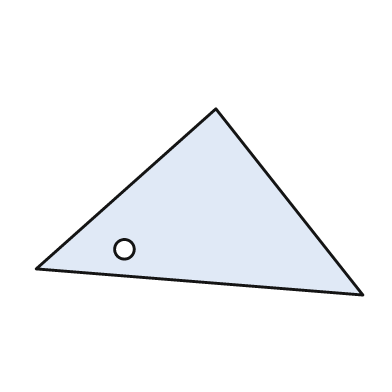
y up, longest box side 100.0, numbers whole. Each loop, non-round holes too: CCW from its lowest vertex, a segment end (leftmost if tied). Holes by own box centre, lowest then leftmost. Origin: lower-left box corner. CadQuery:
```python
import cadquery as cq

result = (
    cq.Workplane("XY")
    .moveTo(100.0, 0.0)
    .lineTo(55.0, 57.0)
    .lineTo(0.0, 8.0)
    .close()
    .moveTo(27.0, 14.0)
    .circle(3.0)
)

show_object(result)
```